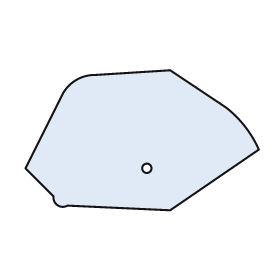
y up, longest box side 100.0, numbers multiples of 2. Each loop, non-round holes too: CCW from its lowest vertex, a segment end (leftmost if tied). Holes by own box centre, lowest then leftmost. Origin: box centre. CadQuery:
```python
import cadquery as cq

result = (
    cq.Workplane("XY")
    .moveTo(12.0, -30.0)
    .lineTo(50.0, -4.0)
    .threePointArc((44.0, 6.0), (36.0, 14.0))
    .lineTo(12.0, 30.0)
    .lineTo(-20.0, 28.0)
    .threePointArc((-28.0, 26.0), (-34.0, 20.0))
    .lineTo(-50.0, -12.0)
    .lineTo(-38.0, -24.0)
    .threePointArc((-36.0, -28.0), (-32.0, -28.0))
    .close()
    .moveTo(2.0, -12.0)
    .circle(2.0)
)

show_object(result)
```